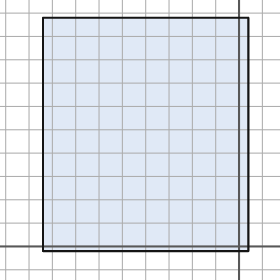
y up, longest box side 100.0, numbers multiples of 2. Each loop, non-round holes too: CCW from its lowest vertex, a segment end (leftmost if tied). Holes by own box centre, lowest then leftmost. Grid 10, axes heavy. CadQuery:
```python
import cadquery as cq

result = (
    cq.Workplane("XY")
    .moveTo(-84.0, -2.0)
    .lineTo(4.0, -2.0)
    .lineTo(4.0, 98.0)
    .lineTo(-84.0, 98.0)
    .close()
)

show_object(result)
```